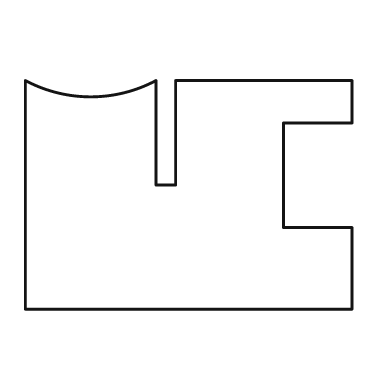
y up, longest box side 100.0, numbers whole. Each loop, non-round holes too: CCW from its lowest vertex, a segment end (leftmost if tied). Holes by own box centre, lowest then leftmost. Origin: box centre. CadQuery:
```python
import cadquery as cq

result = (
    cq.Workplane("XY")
    .moveTo(-50.0, -35.0)
    .lineTo(50.0, -35.0)
    .lineTo(50.0, -10.0)
    .lineTo(29.0, -10.0)
    .lineTo(29.0, 22.0)
    .lineTo(50.0, 22.0)
    .lineTo(50.0, 35.0)
    .lineTo(-4.0, 35.0)
    .lineTo(-4.0, 3.0)
    .lineTo(-10.0, 3.0)
    .lineTo(-10.0, 35.0)
    .threePointArc((-30.0, 30.0), (-50.0, 35.0))
    .close()
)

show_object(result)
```